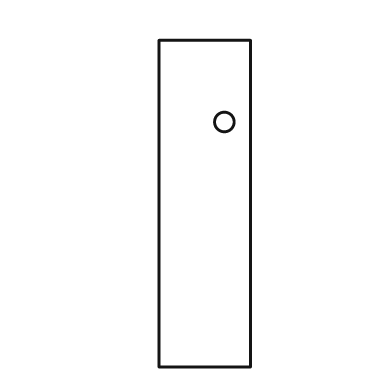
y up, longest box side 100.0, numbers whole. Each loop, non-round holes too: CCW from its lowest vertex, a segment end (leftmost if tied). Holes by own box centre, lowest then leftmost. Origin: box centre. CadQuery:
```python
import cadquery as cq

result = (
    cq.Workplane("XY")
    .moveTo(-14.0, -50.0)
    .lineTo(14.0, -50.0)
    .lineTo(14.0, 50.0)
    .lineTo(-14.0, 50.0)
    .close()
    .moveTo(6.0, 25.0)
    .circle(3.0)
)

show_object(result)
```